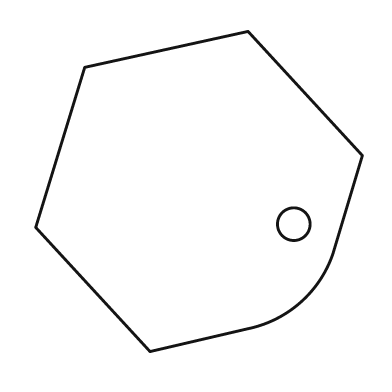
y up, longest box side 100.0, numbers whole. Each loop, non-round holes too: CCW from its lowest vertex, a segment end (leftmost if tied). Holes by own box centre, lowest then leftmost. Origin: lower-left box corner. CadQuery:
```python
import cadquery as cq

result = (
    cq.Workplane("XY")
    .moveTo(35.0, 0.0)
    .lineTo(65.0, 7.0)
    .threePointArc((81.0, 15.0), (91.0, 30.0))
    .lineTo(100.0, 60.0)
    .lineTo(65.0, 98.0)
    .lineTo(15.0, 87.0)
    .lineTo(0.0, 38.0)
    .close()
    .moveTo(79.0, 39.0)
    .circle(5.0)
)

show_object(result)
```